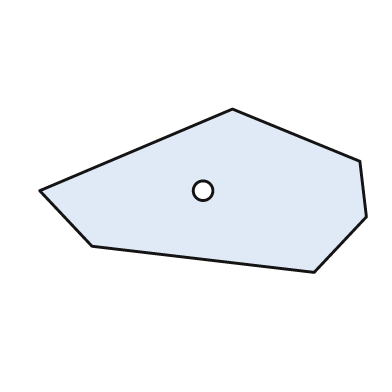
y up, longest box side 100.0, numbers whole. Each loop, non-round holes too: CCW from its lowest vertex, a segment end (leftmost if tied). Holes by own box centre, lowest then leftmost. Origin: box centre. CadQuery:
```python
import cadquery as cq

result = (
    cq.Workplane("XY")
    .moveTo(34.0, -25.0)
    .lineTo(50.0, -8.0)
    .lineTo(48.0, 9.0)
    .lineTo(9.0, 25.0)
    .lineTo(-50.0, 0.0)
    .lineTo(-34.0, -17.0)
    .close()
    .moveTo(0.0, 0.0)
    .circle(3.0)
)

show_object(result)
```